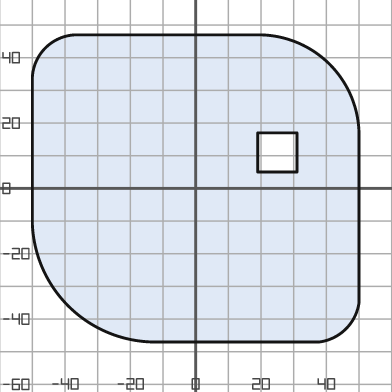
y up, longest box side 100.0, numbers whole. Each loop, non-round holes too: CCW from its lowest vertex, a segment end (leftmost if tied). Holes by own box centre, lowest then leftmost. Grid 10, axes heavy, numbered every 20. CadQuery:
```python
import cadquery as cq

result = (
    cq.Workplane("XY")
    .moveTo(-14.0, -47.0)
    .lineTo(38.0, -47.0)
    .threePointArc((46.0, -43.0), (50.0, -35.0))
    .lineTo(50.0, 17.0)
    .threePointArc((41.0, 38.0), (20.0, 47.0))
    .lineTo(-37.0, 47.0)
    .threePointArc((-46.0, 43.0), (-50.0, 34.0))
    .lineTo(-50.0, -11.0)
    .threePointArc((-39.0, -36.0), (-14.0, -47.0))
    .close()
    .moveTo(19.0, 5.0)
    .lineTo(31.0, 5.0)
    .lineTo(31.0, 17.0)
    .lineTo(19.0, 17.0)
    .close()
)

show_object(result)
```